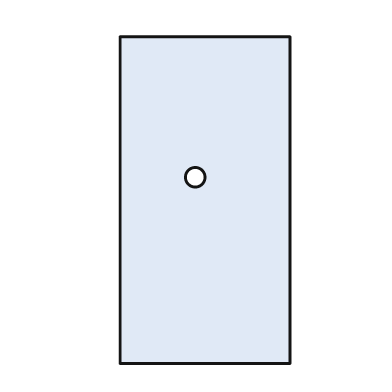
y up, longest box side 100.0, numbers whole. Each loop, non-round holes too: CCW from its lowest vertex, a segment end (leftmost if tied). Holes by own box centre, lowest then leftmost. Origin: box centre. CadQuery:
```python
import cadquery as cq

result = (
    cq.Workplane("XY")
    .moveTo(-26.0, -50.0)
    .lineTo(26.0, -50.0)
    .lineTo(26.0, 50.0)
    .lineTo(-26.0, 50.0)
    .close()
    .moveTo(-3.0, 7.0)
    .circle(3.0)
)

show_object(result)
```